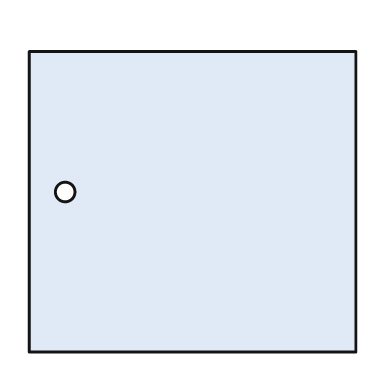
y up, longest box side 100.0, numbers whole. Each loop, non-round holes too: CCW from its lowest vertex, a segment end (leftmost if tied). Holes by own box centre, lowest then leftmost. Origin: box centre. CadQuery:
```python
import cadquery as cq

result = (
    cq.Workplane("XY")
    .moveTo(-50.0, -46.0)
    .lineTo(50.0, -46.0)
    .lineTo(50.0, 46.0)
    .lineTo(-50.0, 46.0)
    .close()
    .moveTo(-39.0, 3.0)
    .circle(3.0)
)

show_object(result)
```